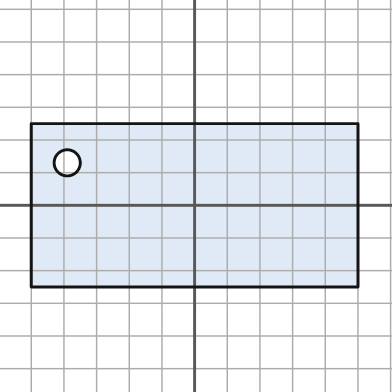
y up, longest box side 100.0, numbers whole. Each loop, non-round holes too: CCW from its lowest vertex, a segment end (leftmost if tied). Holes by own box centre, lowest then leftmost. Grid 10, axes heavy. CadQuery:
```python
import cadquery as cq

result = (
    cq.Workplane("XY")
    .moveTo(-50.0, -25.0)
    .lineTo(50.0, -25.0)
    .lineTo(50.0, 25.0)
    .lineTo(-50.0, 25.0)
    .close()
    .moveTo(-39.0, 13.0)
    .circle(4.0)
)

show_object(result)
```